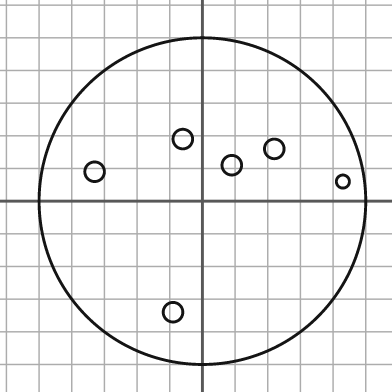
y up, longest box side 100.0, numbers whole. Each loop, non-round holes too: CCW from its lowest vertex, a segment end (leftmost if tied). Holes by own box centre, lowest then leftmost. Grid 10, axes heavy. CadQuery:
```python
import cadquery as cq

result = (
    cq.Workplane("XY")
    .moveTo(0.0, 0.0)
    .circle(50.0)
    .moveTo(-9.0, -34.0)
    .circle(3.0)
    .moveTo(43.0, 6.0)
    .circle(2.0)
    .moveTo(-33.0, 9.0)
    .circle(3.0)
    .moveTo(9.0, 11.0)
    .circle(3.0)
    .moveTo(22.0, 16.0)
    .circle(3.0)
    .moveTo(-6.0, 19.0)
    .circle(3.0)
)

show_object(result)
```